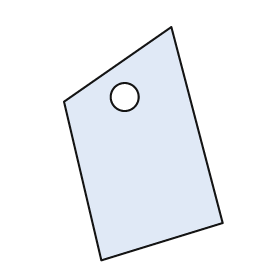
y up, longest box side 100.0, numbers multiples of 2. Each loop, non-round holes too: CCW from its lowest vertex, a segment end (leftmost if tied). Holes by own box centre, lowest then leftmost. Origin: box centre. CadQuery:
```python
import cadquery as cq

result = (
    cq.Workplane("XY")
    .moveTo(-18.0, -50.0)
    .lineTo(34.0, -34.0)
    .lineTo(12.0, 50.0)
    .lineTo(-34.0, 18.0)
    .close()
    .moveTo(-8.0, 20.0)
    .circle(6.0)
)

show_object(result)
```